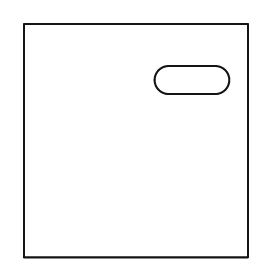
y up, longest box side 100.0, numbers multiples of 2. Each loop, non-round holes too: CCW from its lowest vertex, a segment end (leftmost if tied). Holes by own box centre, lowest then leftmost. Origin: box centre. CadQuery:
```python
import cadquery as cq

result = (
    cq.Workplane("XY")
    .moveTo(-48.0, -50.0)
    .lineTo(48.0, -50.0)
    .lineTo(48.0, 50.0)
    .lineTo(-48.0, 50.0)
    .close()
    .moveTo(14.0, 20.0)
    .lineTo(34.0, 20.0)
    .threePointArc((40.0, 26.0), (34.0, 32.0))
    .lineTo(14.0, 32.0)
    .threePointArc((8.0, 26.0), (14.0, 20.0))
    .close()
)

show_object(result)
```